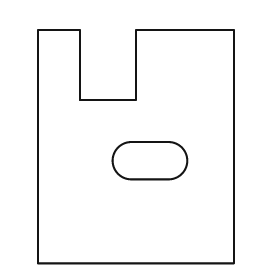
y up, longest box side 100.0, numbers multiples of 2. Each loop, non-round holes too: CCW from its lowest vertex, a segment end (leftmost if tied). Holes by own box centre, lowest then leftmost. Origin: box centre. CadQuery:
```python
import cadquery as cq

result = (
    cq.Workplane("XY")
    .moveTo(-42.0, -50.0)
    .lineTo(42.0, -50.0)
    .lineTo(42.0, 50.0)
    .lineTo(0.0, 50.0)
    .lineTo(0.0, 20.0)
    .lineTo(-24.0, 20.0)
    .lineTo(-24.0, 50.0)
    .lineTo(-42.0, 50.0)
    .close()
    .moveTo(-2.0, -14.0)
    .lineTo(14.0, -14.0)
    .threePointArc((22.0, -6.0), (14.0, 2.0))
    .lineTo(-2.0, 2.0)
    .threePointArc((-10.0, -6.0), (-2.0, -14.0))
    .close()
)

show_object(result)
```